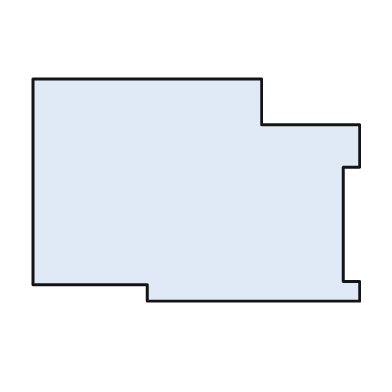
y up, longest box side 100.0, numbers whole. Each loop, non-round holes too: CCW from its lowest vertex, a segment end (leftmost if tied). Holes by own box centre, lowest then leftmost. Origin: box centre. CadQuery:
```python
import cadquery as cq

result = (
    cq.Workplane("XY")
    .moveTo(-15.0, -34.0)
    .lineTo(50.0, -34.0)
    .lineTo(50.0, -28.0)
    .lineTo(45.0, -28.0)
    .lineTo(45.0, 7.0)
    .lineTo(50.0, 7.0)
    .lineTo(50.0, 20.0)
    .lineTo(20.0, 20.0)
    .lineTo(20.0, 34.0)
    .lineTo(-50.0, 34.0)
    .lineTo(-50.0, -29.0)
    .lineTo(-15.0, -29.0)
    .close()
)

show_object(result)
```